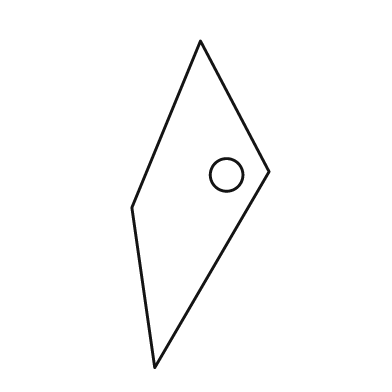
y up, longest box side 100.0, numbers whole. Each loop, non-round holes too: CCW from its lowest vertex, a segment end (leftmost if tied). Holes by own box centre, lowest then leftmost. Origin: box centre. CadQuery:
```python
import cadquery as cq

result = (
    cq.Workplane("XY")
    .moveTo(-14.0, -50.0)
    .lineTo(21.0, 10.0)
    .lineTo(0.0, 50.0)
    .lineTo(-21.0, -1.0)
    .close()
    .moveTo(8.0, 9.0)
    .circle(5.0)
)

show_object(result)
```